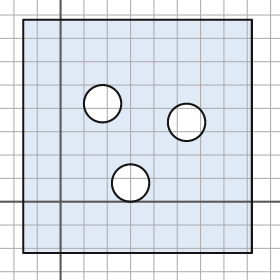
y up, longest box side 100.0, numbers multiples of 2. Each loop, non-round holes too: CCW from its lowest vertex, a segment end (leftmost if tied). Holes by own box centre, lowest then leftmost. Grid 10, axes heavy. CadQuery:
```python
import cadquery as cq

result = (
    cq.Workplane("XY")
    .moveTo(-16.0, -22.0)
    .lineTo(82.0, -22.0)
    .lineTo(82.0, 78.0)
    .lineTo(-16.0, 78.0)
    .close()
    .moveTo(30.0, 8.0)
    .circle(8.0)
    .moveTo(54.0, 34.0)
    .circle(8.0)
    .moveTo(18.0, 42.0)
    .circle(8.0)
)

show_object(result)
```